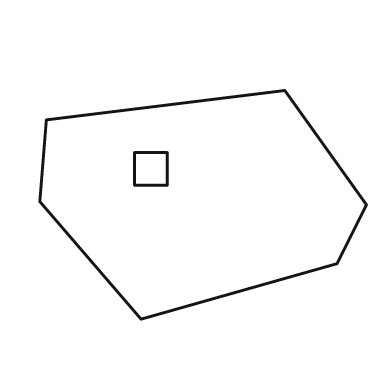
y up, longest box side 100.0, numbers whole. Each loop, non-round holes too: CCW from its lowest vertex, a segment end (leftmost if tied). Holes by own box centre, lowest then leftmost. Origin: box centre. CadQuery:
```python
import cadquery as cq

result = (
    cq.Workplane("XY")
    .moveTo(-19.0, -35.0)
    .lineTo(41.0, -18.0)
    .lineTo(50.0, 0.0)
    .lineTo(25.0, 35.0)
    .lineTo(-48.0, 26.0)
    .lineTo(-50.0, 1.0)
    .close()
    .moveTo(-21.0, 6.0)
    .lineTo(-11.0, 6.0)
    .lineTo(-11.0, 16.0)
    .lineTo(-21.0, 16.0)
    .close()
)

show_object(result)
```